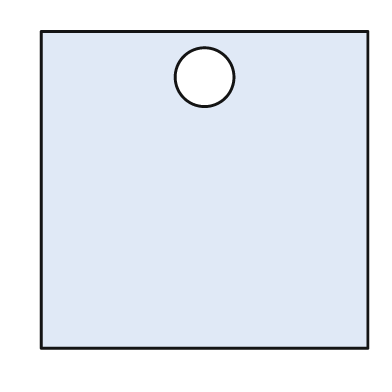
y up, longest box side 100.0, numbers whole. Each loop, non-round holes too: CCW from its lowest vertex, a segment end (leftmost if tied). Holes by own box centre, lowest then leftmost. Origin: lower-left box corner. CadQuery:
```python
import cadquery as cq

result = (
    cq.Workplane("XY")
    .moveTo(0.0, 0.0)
    .lineTo(100.0, 0.0)
    .lineTo(100.0, 97.0)
    .lineTo(0.0, 97.0)
    .close()
    .moveTo(50.0, 83.0)
    .circle(9.0)
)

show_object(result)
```